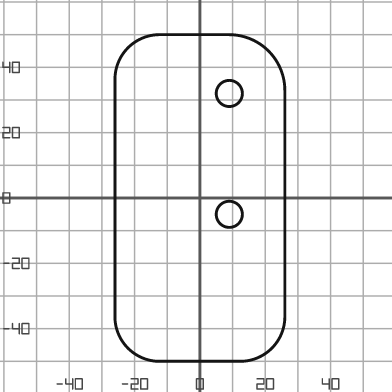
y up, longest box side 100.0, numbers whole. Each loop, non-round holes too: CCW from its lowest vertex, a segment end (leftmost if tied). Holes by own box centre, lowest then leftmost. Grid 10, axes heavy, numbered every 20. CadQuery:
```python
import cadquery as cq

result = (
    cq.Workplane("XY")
    .moveTo(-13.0, -50.0)
    .lineTo(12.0, -50.0)
    .threePointArc((22.0, -46.0), (26.0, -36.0))
    .lineTo(26.0, 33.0)
    .threePointArc((21.0, 45.0), (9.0, 50.0))
    .lineTo(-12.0, 50.0)
    .threePointArc((-22.0, 46.0), (-26.0, 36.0))
    .lineTo(-26.0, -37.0)
    .threePointArc((-22.0, -46.0), (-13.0, -50.0))
    .close()
    .moveTo(9.0, -5.0)
    .circle(4.0)
    .moveTo(9.0, 32.0)
    .circle(4.0)
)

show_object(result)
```